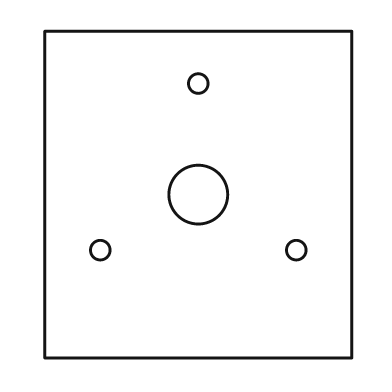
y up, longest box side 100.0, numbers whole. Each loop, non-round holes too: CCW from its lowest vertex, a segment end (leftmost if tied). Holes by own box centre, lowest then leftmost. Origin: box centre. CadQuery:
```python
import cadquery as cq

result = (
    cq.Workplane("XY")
    .moveTo(-47.0, -50.0)
    .lineTo(47.0, -50.0)
    .lineTo(47.0, 50.0)
    .lineTo(-47.0, 50.0)
    .close()
    .moveTo(-30.0, -17.0)
    .circle(3.0)
    .moveTo(30.0, -17.0)
    .circle(3.0)
    .moveTo(0.0, 0.0)
    .circle(9.0)
    .moveTo(0.0, 34.0)
    .circle(3.0)
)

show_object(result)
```